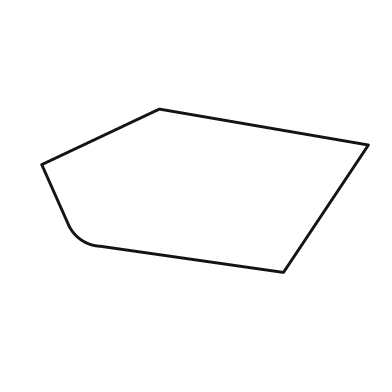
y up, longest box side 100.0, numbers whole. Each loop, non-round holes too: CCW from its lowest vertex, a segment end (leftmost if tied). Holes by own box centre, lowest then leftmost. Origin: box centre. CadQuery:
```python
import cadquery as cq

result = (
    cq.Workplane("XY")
    .moveTo(24.0, -25.0)
    .lineTo(50.0, 14.0)
    .lineTo(-14.0, 25.0)
    .lineTo(-50.0, 8.0)
    .lineTo(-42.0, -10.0)
    .threePointArc((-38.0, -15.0), (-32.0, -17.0))
    .close()
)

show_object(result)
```